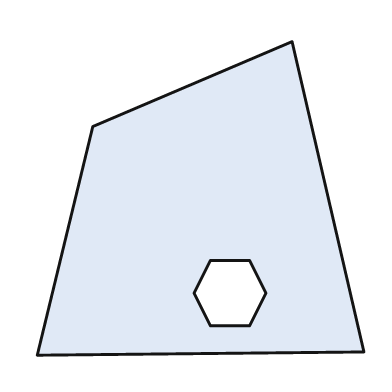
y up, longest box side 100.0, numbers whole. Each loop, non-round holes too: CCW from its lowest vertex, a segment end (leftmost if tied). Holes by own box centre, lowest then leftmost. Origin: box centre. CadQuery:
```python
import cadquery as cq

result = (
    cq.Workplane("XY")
    .moveTo(-50.0, -48.0)
    .lineTo(50.0, -47.0)
    .lineTo(28.0, 48.0)
    .lineTo(-33.0, 22.0)
    .close()
    .moveTo(3.0, -39.0)
    .lineTo(15.0, -39.0)
    .lineTo(20.0, -29.0)
    .lineTo(15.0, -19.0)
    .lineTo(3.0, -19.0)
    .lineTo(-2.0, -29.0)
    .close()
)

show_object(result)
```